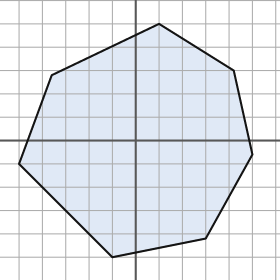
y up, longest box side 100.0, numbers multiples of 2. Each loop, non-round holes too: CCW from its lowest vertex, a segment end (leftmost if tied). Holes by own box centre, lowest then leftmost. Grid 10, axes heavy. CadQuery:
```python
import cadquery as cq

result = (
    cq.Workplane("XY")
    .moveTo(-10.0, -50.0)
    .lineTo(30.0, -42.0)
    .lineTo(50.0, -6.0)
    .lineTo(42.0, 30.0)
    .lineTo(10.0, 50.0)
    .lineTo(-36.0, 28.0)
    .lineTo(-50.0, -10.0)
    .close()
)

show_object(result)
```